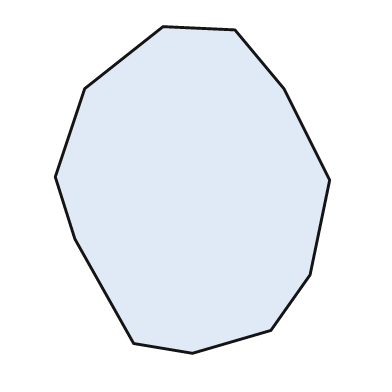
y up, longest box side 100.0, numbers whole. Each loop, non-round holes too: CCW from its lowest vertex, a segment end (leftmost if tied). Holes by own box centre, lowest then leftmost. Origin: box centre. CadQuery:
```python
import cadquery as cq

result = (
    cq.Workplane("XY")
    .moveTo(0.0, -50.0)
    .lineTo(24.0, -43.0)
    .lineTo(36.0, -26.0)
    .lineTo(42.0, 3.0)
    .lineTo(28.0, 31.0)
    .lineTo(13.0, 49.0)
    .lineTo(-9.0, 50.0)
    .lineTo(-33.0, 31.0)
    .lineTo(-42.0, 4.0)
    .lineTo(-36.0, -15.0)
    .lineTo(-18.0, -47.0)
    .close()
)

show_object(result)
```